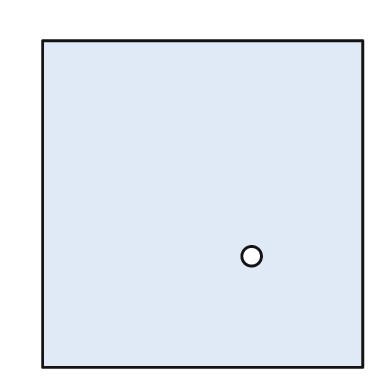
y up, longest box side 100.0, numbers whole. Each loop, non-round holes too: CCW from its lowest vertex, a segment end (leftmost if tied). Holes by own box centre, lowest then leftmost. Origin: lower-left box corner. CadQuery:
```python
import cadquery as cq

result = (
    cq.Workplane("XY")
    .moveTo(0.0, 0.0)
    .lineTo(98.0, 0.0)
    .lineTo(98.0, 100.0)
    .lineTo(0.0, 100.0)
    .close()
    .moveTo(64.0, 34.0)
    .circle(3.0)
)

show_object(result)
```